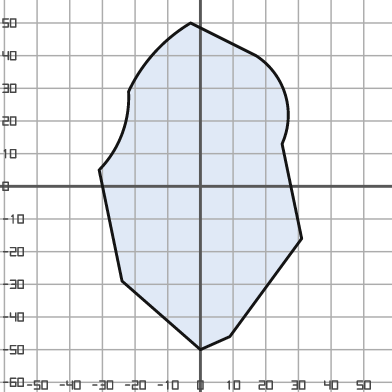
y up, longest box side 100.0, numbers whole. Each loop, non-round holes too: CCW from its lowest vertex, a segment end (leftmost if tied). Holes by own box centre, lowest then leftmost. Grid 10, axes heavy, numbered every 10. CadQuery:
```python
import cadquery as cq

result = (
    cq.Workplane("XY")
    .moveTo(0.0, -50.0)
    .lineTo(9.0, -46.0)
    .lineTo(31.0, -16.0)
    .lineTo(25.0, 13.0)
    .threePointArc((26.0, 28.0), (17.0, 40.0))
    .lineTo(-3.0, 50.0)
    .threePointArc((-14.0, 41.0), (-22.0, 29.0))
    .threePointArc((-24.0, 16.0), (-31.0, 5.0))
    .lineTo(-24.0, -29.0)
    .close()
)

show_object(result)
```